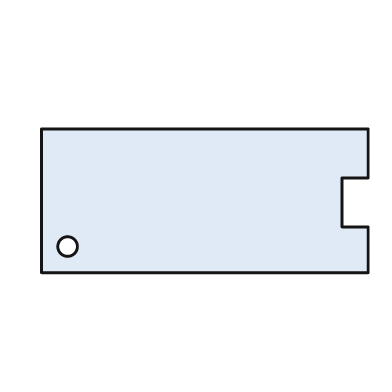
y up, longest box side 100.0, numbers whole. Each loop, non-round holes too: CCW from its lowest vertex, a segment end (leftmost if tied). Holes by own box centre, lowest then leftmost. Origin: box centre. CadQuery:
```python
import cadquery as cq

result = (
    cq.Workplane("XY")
    .moveTo(-50.0, -22.0)
    .lineTo(50.0, -22.0)
    .lineTo(50.0, -8.0)
    .lineTo(42.0, -8.0)
    .lineTo(42.0, 7.0)
    .lineTo(50.0, 7.0)
    .lineTo(50.0, 22.0)
    .lineTo(-50.0, 22.0)
    .close()
    .moveTo(-42.0, -14.0)
    .circle(3.0)
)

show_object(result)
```